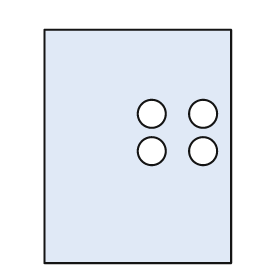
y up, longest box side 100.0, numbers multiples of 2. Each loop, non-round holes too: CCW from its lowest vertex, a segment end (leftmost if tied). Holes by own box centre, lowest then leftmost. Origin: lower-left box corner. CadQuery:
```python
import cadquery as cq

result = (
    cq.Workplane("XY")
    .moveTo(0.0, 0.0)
    .lineTo(80.0, 0.0)
    .lineTo(80.0, 100.0)
    .lineTo(0.0, 100.0)
    .close()
    .moveTo(46.0, 48.0)
    .circle(6.0)
    .moveTo(68.0, 48.0)
    .circle(6.0)
    .moveTo(46.0, 64.0)
    .circle(6.0)
    .moveTo(68.0, 64.0)
    .circle(6.0)
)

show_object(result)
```